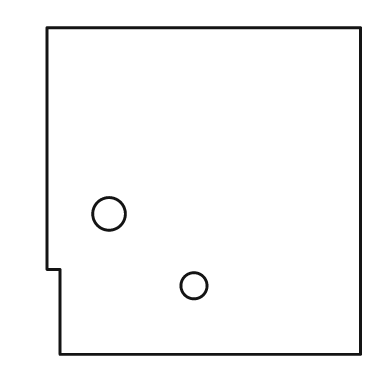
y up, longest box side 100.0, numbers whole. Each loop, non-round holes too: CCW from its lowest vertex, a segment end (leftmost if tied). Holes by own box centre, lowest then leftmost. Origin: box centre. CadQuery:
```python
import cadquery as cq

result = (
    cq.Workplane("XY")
    .moveTo(-44.0, -50.0)
    .lineTo(48.0, -50.0)
    .lineTo(48.0, 50.0)
    .lineTo(-48.0, 50.0)
    .lineTo(-48.0, -24.0)
    .lineTo(-44.0, -24.0)
    .close()
    .moveTo(-3.0, -29.0)
    .circle(4.0)
    .moveTo(-29.0, -7.0)
    .circle(5.0)
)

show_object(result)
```